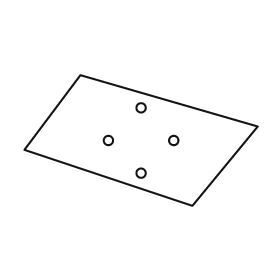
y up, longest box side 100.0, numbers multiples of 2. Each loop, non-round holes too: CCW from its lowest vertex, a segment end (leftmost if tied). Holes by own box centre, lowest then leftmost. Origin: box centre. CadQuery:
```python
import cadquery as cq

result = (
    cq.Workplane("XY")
    .moveTo(22.0, -28.0)
    .lineTo(50.0, 6.0)
    .lineTo(-26.0, 28.0)
    .lineTo(-50.0, -4.0)
    .close()
    .moveTo(0.0, -14.0)
    .circle(2.0)
    .moveTo(-14.0, 0.0)
    .circle(2.0)
    .moveTo(14.0, 0.0)
    .circle(2.0)
    .moveTo(0.0, 14.0)
    .circle(2.0)
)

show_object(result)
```